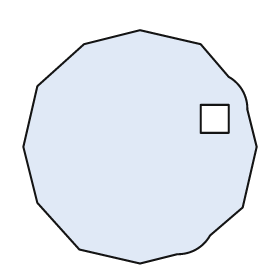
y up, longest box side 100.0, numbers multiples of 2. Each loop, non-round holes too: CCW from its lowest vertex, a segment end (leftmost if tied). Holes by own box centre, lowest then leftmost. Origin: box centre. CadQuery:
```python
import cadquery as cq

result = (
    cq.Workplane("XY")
    .moveTo(0.0, -50.0)
    .lineTo(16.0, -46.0)
    .threePointArc((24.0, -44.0), (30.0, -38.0))
    .lineTo(44.0, -26.0)
    .lineTo(50.0, 0.0)
    .lineTo(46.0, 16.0)
    .threePointArc((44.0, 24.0), (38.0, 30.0))
    .lineTo(26.0, 44.0)
    .lineTo(0.0, 50.0)
    .lineTo(-24.0, 44.0)
    .lineTo(-44.0, 26.0)
    .lineTo(-50.0, 0.0)
    .lineTo(-44.0, -24.0)
    .lineTo(-26.0, -44.0)
    .close()
    .moveTo(26.0, 6.0)
    .lineTo(38.0, 6.0)
    .lineTo(38.0, 18.0)
    .lineTo(26.0, 18.0)
    .close()
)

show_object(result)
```